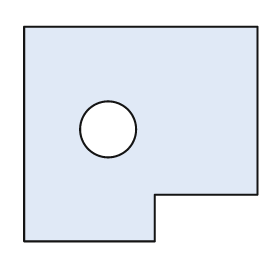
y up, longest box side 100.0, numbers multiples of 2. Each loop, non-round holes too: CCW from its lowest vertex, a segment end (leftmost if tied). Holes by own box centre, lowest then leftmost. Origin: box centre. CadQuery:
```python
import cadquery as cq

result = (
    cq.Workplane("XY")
    .moveTo(-50.0, -46.0)
    .lineTo(6.0, -46.0)
    .lineTo(6.0, -26.0)
    .lineTo(50.0, -26.0)
    .lineTo(50.0, 46.0)
    .lineTo(-50.0, 46.0)
    .close()
    .moveTo(-14.0, 2.0)
    .circle(12.0)
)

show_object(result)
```